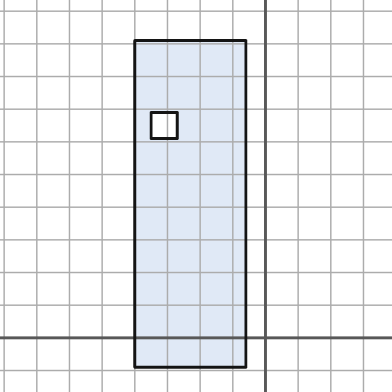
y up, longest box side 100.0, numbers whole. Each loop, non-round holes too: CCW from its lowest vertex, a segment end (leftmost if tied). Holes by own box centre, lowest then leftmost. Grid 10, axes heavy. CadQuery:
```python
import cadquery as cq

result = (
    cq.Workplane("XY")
    .moveTo(-40.0, -9.0)
    .lineTo(-6.0, -9.0)
    .lineTo(-6.0, 91.0)
    .lineTo(-40.0, 91.0)
    .close()
    .moveTo(-35.0, 61.0)
    .lineTo(-27.0, 61.0)
    .lineTo(-27.0, 69.0)
    .lineTo(-35.0, 69.0)
    .close()
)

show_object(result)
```